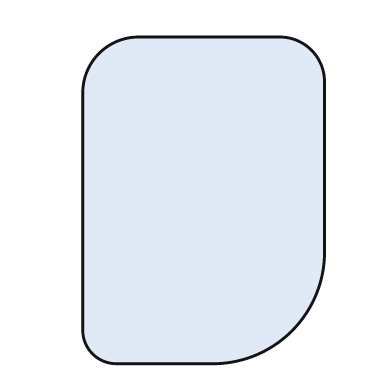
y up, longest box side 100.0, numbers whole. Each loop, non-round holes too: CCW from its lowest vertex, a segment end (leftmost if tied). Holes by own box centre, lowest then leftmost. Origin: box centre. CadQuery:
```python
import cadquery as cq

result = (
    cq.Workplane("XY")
    .moveTo(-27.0, -50.0)
    .lineTo(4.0, -50.0)
    .threePointArc((27.0, -40.0), (37.0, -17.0))
    .lineTo(37.0, 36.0)
    .threePointArc((33.0, 46.0), (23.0, 50.0))
    .lineTo(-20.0, 50.0)
    .threePointArc((-32.0, 45.0), (-37.0, 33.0))
    .lineTo(-37.0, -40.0)
    .threePointArc((-34.0, -47.0), (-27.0, -50.0))
    .close()
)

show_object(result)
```